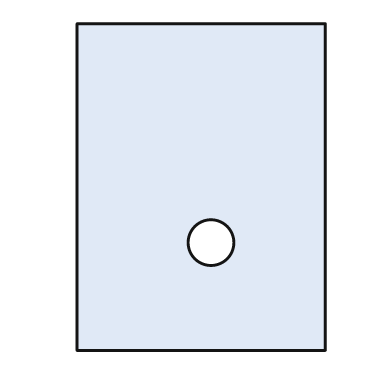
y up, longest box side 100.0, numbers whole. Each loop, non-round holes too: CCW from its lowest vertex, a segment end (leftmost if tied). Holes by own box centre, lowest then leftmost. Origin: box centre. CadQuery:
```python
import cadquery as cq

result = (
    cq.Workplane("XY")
    .moveTo(-38.0, -50.0)
    .lineTo(38.0, -50.0)
    .lineTo(38.0, 50.0)
    .lineTo(-38.0, 50.0)
    .close()
    .moveTo(3.0, -17.0)
    .circle(7.0)
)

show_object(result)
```